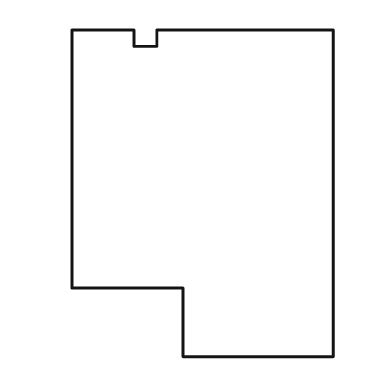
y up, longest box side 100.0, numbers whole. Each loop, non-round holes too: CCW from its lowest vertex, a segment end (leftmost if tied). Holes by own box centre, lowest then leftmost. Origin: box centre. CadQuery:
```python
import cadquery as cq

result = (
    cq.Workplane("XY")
    .moveTo(-6.0, -50.0)
    .lineTo(40.0, -50.0)
    .lineTo(40.0, 50.0)
    .lineTo(-14.0, 50.0)
    .lineTo(-14.0, 45.0)
    .lineTo(-21.0, 45.0)
    .lineTo(-21.0, 50.0)
    .lineTo(-40.0, 50.0)
    .lineTo(-40.0, -29.0)
    .lineTo(-6.0, -29.0)
    .close()
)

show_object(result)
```